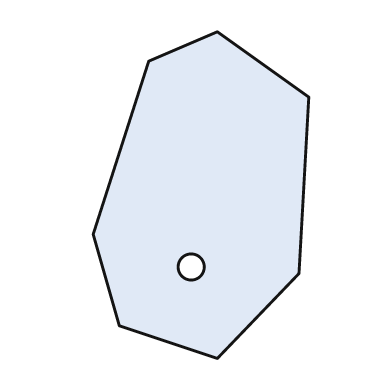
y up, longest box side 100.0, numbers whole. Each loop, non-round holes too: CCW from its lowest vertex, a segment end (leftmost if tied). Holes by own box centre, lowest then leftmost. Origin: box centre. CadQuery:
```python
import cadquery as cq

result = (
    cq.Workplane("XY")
    .moveTo(5.0, -50.0)
    .lineTo(30.0, -24.0)
    .lineTo(33.0, 30.0)
    .lineTo(5.0, 50.0)
    .lineTo(-16.0, 41.0)
    .lineTo(-33.0, -12.0)
    .lineTo(-25.0, -40.0)
    .close()
    .moveTo(-3.0, -22.0)
    .circle(4.0)
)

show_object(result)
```